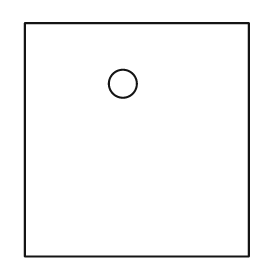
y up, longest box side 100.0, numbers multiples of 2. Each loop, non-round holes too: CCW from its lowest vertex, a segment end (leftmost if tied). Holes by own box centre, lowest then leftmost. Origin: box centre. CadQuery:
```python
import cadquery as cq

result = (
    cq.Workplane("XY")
    .moveTo(-48.0, -50.0)
    .lineTo(48.0, -50.0)
    .lineTo(48.0, 50.0)
    .lineTo(-48.0, 50.0)
    .close()
    .moveTo(-6.0, 24.0)
    .circle(6.0)
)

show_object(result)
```